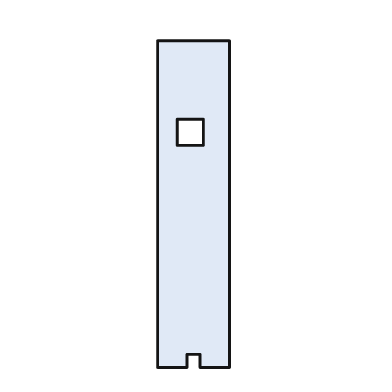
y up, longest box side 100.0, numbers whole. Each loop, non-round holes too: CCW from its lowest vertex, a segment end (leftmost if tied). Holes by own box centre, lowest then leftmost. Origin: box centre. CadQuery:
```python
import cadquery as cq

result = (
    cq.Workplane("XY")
    .moveTo(-11.0, -50.0)
    .lineTo(-2.0, -50.0)
    .lineTo(-2.0, -46.0)
    .lineTo(2.0, -46.0)
    .lineTo(2.0, -50.0)
    .lineTo(11.0, -50.0)
    .lineTo(11.0, 50.0)
    .lineTo(-11.0, 50.0)
    .close()
    .moveTo(-5.0, 18.0)
    .lineTo(3.0, 18.0)
    .lineTo(3.0, 26.0)
    .lineTo(-5.0, 26.0)
    .close()
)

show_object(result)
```